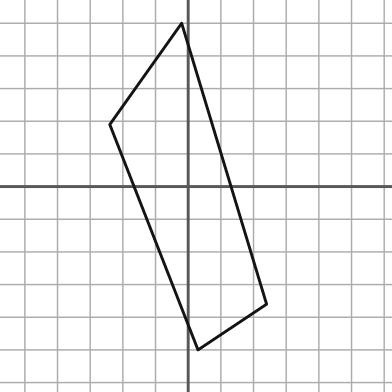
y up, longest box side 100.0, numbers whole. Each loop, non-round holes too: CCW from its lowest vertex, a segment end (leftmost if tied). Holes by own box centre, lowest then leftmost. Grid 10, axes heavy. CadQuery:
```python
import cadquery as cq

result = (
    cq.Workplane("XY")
    .moveTo(3.0, -50.0)
    .lineTo(24.0, -36.0)
    .lineTo(-2.0, 50.0)
    .lineTo(-24.0, 19.0)
    .close()
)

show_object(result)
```